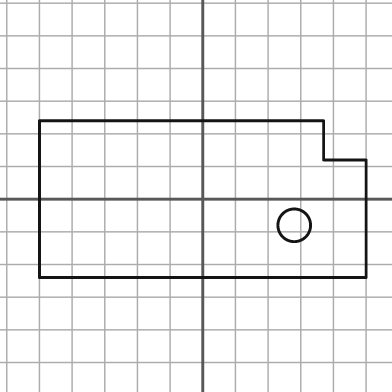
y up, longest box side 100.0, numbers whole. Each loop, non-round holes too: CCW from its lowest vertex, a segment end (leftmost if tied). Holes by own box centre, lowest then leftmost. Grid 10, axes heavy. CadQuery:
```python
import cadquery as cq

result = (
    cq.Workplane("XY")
    .moveTo(-50.0, -24.0)
    .lineTo(50.0, -24.0)
    .lineTo(50.0, 12.0)
    .lineTo(37.0, 12.0)
    .lineTo(37.0, 24.0)
    .lineTo(-50.0, 24.0)
    .close()
    .moveTo(28.0, -8.0)
    .circle(5.0)
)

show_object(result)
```